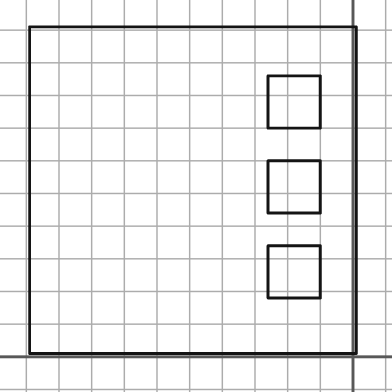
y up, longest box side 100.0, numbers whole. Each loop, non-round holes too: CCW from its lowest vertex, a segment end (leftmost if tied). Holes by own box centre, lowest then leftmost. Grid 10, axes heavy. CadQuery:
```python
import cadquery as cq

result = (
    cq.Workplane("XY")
    .moveTo(-99.0, 1.0)
    .lineTo(1.0, 1.0)
    .lineTo(1.0, 101.0)
    .lineTo(-99.0, 101.0)
    .close()
    .moveTo(-26.0, 18.0)
    .lineTo(-10.0, 18.0)
    .lineTo(-10.0, 34.0)
    .lineTo(-26.0, 34.0)
    .close()
    .moveTo(-26.0, 44.0)
    .lineTo(-10.0, 44.0)
    .lineTo(-10.0, 60.0)
    .lineTo(-26.0, 60.0)
    .close()
    .moveTo(-26.0, 70.0)
    .lineTo(-10.0, 70.0)
    .lineTo(-10.0, 86.0)
    .lineTo(-26.0, 86.0)
    .close()
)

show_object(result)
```